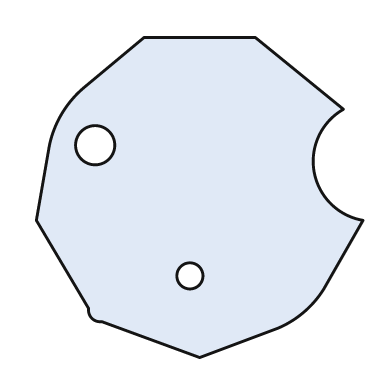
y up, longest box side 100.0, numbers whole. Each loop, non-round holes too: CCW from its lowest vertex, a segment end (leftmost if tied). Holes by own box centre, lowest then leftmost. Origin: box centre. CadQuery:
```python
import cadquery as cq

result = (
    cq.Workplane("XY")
    .moveTo(0.0, -49.0)
    .lineTo(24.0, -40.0)
    .threePointArc((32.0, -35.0), (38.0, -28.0))
    .lineTo(50.0, -7.0)
    .threePointArc((35.0, 8.0), (44.0, 27.0))
    .lineTo(17.0, 49.0)
    .lineTo(-17.0, 49.0)
    .lineTo(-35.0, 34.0)
    .threePointArc((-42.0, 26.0), (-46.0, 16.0))
    .lineTo(-50.0, -7.0)
    .lineTo(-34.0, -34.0)
    .threePointArc((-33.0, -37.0), (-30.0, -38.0))
    .close()
    .moveTo(-3.0, -24.0)
    .circle(4.0)
    .moveTo(-32.0, 16.0)
    .circle(6.0)
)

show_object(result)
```